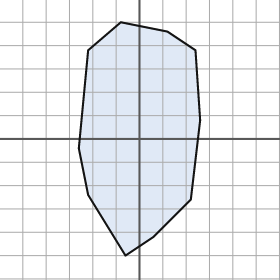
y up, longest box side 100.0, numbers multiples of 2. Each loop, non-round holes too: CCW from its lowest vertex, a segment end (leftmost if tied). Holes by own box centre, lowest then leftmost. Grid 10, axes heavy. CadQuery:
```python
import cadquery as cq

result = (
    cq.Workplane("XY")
    .moveTo(-6.0, -50.0)
    .lineTo(6.0, -42.0)
    .lineTo(22.0, -26.0)
    .lineTo(26.0, 8.0)
    .lineTo(24.0, 38.0)
    .lineTo(12.0, 46.0)
    .lineTo(-8.0, 50.0)
    .lineTo(-22.0, 38.0)
    .lineTo(-26.0, -4.0)
    .lineTo(-22.0, -24.0)
    .close()
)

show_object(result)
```